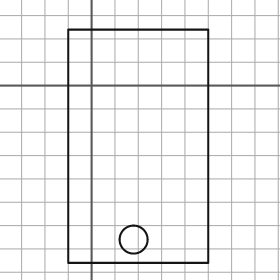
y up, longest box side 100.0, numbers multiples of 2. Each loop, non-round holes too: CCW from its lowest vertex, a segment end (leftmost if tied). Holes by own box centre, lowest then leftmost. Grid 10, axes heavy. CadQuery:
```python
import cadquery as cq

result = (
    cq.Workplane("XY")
    .moveTo(-10.0, -76.0)
    .lineTo(50.0, -76.0)
    .lineTo(50.0, 24.0)
    .lineTo(-10.0, 24.0)
    .close()
    .moveTo(18.0, -66.0)
    .circle(6.0)
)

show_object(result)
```